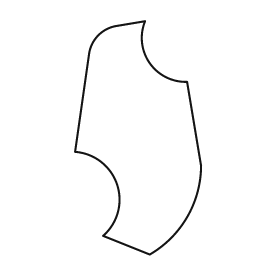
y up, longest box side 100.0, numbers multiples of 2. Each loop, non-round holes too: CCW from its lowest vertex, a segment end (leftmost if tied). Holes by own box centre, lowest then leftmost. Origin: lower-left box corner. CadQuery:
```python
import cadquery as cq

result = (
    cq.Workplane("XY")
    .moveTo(32.0, 0.0)
    .threePointArc((48.0, 16.0), (54.0, 38.0))
    .lineTo(48.0, 74.0)
    .threePointArc((32.0, 82.0), (30.0, 100.0))
    .lineTo(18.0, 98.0)
    .threePointArc((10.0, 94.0), (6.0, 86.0))
    .lineTo(0.0, 44.0)
    .threePointArc((18.0, 30.0), (12.0, 8.0))
    .close()
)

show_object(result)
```